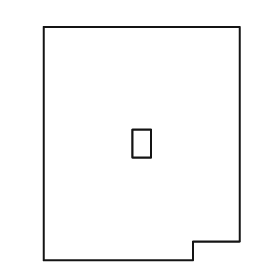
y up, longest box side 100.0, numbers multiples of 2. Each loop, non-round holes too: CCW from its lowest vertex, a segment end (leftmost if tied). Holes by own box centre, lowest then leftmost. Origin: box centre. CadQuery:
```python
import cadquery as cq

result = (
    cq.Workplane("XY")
    .moveTo(-42.0, -50.0)
    .lineTo(22.0, -50.0)
    .lineTo(22.0, -42.0)
    .lineTo(42.0, -42.0)
    .lineTo(42.0, 50.0)
    .lineTo(-42.0, 50.0)
    .close()
    .moveTo(-4.0, -6.0)
    .lineTo(4.0, -6.0)
    .lineTo(4.0, 6.0)
    .lineTo(-4.0, 6.0)
    .close()
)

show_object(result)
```